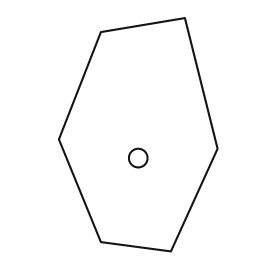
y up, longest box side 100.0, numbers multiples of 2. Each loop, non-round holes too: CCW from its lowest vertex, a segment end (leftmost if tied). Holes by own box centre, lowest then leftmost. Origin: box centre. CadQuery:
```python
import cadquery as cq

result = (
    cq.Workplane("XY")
    .moveTo(14.0, -50.0)
    .lineTo(34.0, -6.0)
    .lineTo(20.0, 50.0)
    .lineTo(-16.0, 44.0)
    .lineTo(-34.0, -2.0)
    .lineTo(-16.0, -46.0)
    .close()
    .moveTo(0.0, -10.0)
    .circle(4.0)
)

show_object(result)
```